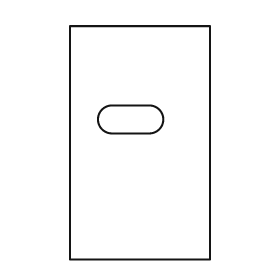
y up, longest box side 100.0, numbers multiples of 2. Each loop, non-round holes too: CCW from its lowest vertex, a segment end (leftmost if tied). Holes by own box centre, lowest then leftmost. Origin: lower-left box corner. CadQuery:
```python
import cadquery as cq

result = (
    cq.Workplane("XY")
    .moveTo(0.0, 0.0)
    .lineTo(60.0, 0.0)
    .lineTo(60.0, 100.0)
    .lineTo(0.0, 100.0)
    .close()
    .moveTo(18.0, 54.0)
    .lineTo(34.0, 54.0)
    .threePointArc((40.0, 60.0), (34.0, 66.0))
    .lineTo(18.0, 66.0)
    .threePointArc((12.0, 60.0), (18.0, 54.0))
    .close()
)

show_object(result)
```